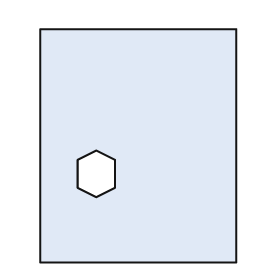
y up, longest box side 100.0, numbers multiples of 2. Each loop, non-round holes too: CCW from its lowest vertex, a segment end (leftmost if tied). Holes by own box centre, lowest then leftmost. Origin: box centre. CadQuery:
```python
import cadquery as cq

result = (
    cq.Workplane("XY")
    .moveTo(-42.0, -50.0)
    .lineTo(42.0, -50.0)
    .lineTo(42.0, 50.0)
    .lineTo(-42.0, 50.0)
    .close()
    .moveTo(-18.0, -22.0)
    .lineTo(-10.0, -18.0)
    .lineTo(-10.0, -6.0)
    .lineTo(-18.0, -2.0)
    .lineTo(-26.0, -6.0)
    .lineTo(-26.0, -18.0)
    .close()
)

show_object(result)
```